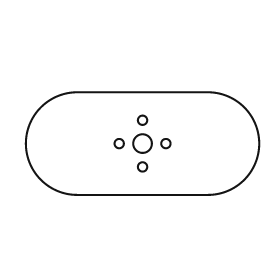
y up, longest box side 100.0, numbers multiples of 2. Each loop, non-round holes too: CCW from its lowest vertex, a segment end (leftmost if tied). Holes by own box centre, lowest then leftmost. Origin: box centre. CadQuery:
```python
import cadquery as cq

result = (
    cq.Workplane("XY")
    .moveTo(-28.0, -22.0)
    .lineTo(28.0, -22.0)
    .threePointArc((50.0, 0.0), (28.0, 22.0))
    .lineTo(-28.0, 22.0)
    .threePointArc((-50.0, 0.0), (-28.0, -22.0))
    .close()
    .moveTo(0.0, -10.0)
    .circle(2.0)
    .moveTo(-10.0, 0.0)
    .circle(2.0)
    .moveTo(0.0, 0.0)
    .circle(4.0)
    .moveTo(10.0, 0.0)
    .circle(2.0)
    .moveTo(0.0, 10.0)
    .circle(2.0)
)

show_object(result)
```